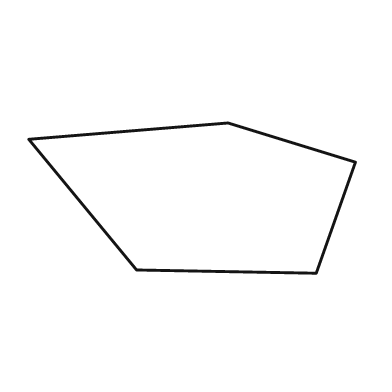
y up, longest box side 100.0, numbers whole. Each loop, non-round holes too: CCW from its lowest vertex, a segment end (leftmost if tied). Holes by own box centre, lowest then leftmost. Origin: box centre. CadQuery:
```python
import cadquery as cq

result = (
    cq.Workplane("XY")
    .moveTo(38.0, -23.0)
    .lineTo(50.0, 11.0)
    .lineTo(11.0, 23.0)
    .lineTo(-50.0, 18.0)
    .lineTo(-17.0, -22.0)
    .close()
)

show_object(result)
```